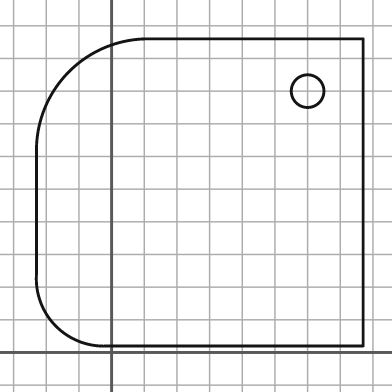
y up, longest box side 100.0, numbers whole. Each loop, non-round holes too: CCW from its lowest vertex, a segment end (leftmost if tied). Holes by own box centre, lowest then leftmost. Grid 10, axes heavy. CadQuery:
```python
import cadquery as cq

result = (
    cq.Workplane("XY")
    .moveTo(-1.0, 2.0)
    .lineTo(77.0, 2.0)
    .lineTo(77.0, 96.0)
    .lineTo(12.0, 96.0)
    .threePointArc((-13.0, 86.0), (-23.0, 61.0))
    .lineTo(-23.0, 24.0)
    .threePointArc((-17.0, 8.0), (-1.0, 2.0))
    .close()
    .moveTo(60.0, 80.0)
    .circle(5.0)
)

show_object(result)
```